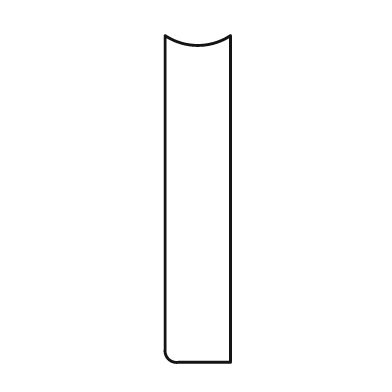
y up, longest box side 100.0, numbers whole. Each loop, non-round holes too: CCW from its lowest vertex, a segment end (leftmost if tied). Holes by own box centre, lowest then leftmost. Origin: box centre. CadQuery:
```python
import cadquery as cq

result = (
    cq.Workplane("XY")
    .moveTo(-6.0, -50.0)
    .lineTo(10.0, -50.0)
    .lineTo(10.0, 50.0)
    .threePointArc((0.0, 47.0), (-10.0, 50.0))
    .lineTo(-10.0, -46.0)
    .threePointArc((-9.0, -49.0), (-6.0, -50.0))
    .close()
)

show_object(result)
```